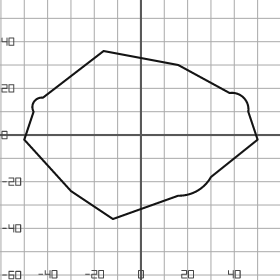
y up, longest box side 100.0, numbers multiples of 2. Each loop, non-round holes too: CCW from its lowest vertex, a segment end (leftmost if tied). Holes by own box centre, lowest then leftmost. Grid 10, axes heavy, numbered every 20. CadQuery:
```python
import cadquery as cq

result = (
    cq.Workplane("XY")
    .moveTo(-12.0, -36.0)
    .lineTo(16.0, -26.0)
    .threePointArc((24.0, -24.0), (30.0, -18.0))
    .lineTo(50.0, -2.0)
    .lineTo(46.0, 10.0)
    .threePointArc((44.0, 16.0), (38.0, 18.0))
    .lineTo(16.0, 30.0)
    .lineTo(-16.0, 36.0)
    .lineTo(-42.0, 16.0)
    .threePointArc((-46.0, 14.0), (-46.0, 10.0))
    .lineTo(-50.0, -2.0)
    .lineTo(-30.0, -24.0)
    .close()
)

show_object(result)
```